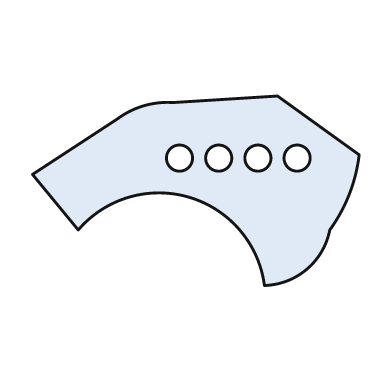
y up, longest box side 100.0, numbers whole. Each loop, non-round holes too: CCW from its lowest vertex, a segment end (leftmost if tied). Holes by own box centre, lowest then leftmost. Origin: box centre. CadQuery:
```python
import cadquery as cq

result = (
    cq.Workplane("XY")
    .moveTo(21.0, -29.0)
    .threePointArc((34.0, -24.0), (41.0, -12.0))
    .threePointArc((47.0, -1.0), (50.0, 11.0))
    .lineTo(25.0, 29.0)
    .lineTo(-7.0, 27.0)
    .threePointArc((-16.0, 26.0), (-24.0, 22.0))
    .lineTo(-50.0, 5.0)
    .lineTo(-36.0, -12.0)
    .threePointArc((-2.0, -2.0), (21.0, -29.0))
    .close()
    .moveTo(-5.0, 10.0)
    .circle(4.0)
    .moveTo(7.0, 10.0)
    .circle(4.0)
    .moveTo(19.0, 10.0)
    .circle(4.0)
    .moveTo(31.0, 10.0)
    .circle(4.0)
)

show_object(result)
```